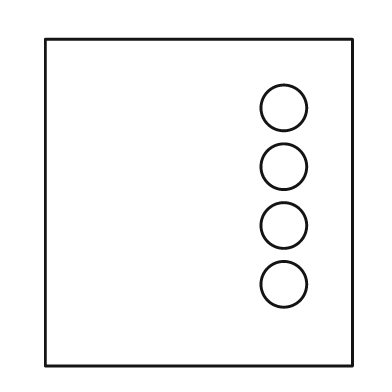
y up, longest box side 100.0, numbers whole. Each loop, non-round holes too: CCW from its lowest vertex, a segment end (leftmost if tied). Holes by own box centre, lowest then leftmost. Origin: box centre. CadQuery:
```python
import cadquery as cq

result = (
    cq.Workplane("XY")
    .moveTo(-47.0, -50.0)
    .lineTo(47.0, -50.0)
    .lineTo(47.0, 50.0)
    .lineTo(-47.0, 50.0)
    .close()
    .moveTo(26.0, -25.0)
    .circle(7.0)
    .moveTo(26.0, -7.0)
    .circle(7.0)
    .moveTo(26.0, 11.0)
    .circle(7.0)
    .moveTo(26.0, 29.0)
    .circle(7.0)
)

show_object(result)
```